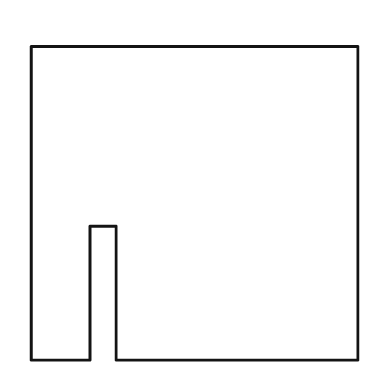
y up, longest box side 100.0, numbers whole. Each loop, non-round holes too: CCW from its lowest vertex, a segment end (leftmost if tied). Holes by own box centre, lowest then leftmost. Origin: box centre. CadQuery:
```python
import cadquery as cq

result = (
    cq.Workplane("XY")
    .moveTo(-50.0, -48.0)
    .lineTo(-32.0, -48.0)
    .lineTo(-32.0, -7.0)
    .lineTo(-24.0, -7.0)
    .lineTo(-24.0, -48.0)
    .lineTo(50.0, -48.0)
    .lineTo(50.0, 48.0)
    .lineTo(-50.0, 48.0)
    .close()
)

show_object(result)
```